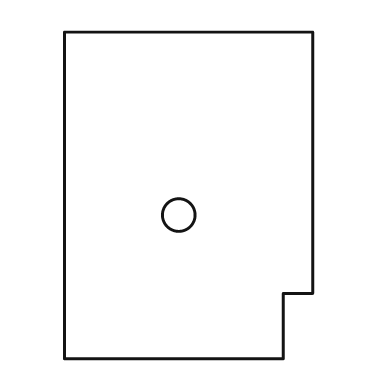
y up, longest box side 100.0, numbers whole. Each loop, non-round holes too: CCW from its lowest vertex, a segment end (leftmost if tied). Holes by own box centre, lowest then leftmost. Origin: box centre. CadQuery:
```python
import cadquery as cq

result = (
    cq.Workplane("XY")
    .moveTo(-38.0, -50.0)
    .lineTo(29.0, -50.0)
    .lineTo(29.0, -30.0)
    .lineTo(38.0, -30.0)
    .lineTo(38.0, 50.0)
    .lineTo(-38.0, 50.0)
    .close()
    .moveTo(-3.0, -6.0)
    .circle(5.0)
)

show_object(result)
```